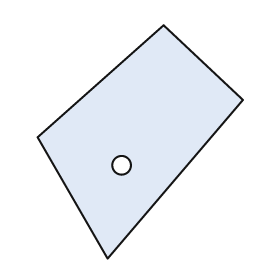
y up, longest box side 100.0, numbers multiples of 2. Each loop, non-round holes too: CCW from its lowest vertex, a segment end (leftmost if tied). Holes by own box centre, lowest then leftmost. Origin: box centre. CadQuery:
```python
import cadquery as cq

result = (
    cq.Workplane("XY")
    .moveTo(-14.0, -50.0)
    .lineTo(44.0, 18.0)
    .lineTo(10.0, 50.0)
    .lineTo(-44.0, 2.0)
    .close()
    .moveTo(-8.0, -10.0)
    .circle(4.0)
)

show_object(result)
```